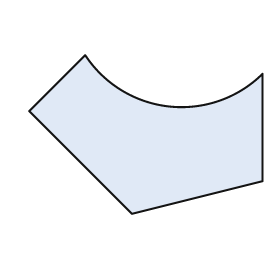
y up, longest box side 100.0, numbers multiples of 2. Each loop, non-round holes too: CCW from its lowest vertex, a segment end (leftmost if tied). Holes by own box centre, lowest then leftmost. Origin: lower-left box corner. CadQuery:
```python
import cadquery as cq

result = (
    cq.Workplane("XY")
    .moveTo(44.0, 0.0)
    .lineTo(100.0, 14.0)
    .lineTo(100.0, 60.0)
    .threePointArc((60.0, 46.0), (24.0, 68.0))
    .lineTo(0.0, 44.0)
    .close()
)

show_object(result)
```